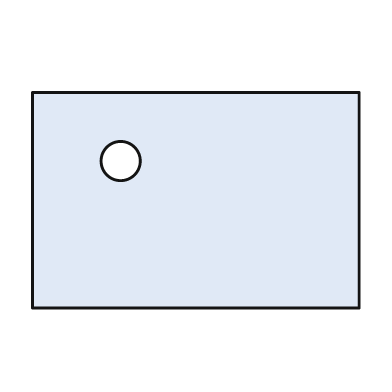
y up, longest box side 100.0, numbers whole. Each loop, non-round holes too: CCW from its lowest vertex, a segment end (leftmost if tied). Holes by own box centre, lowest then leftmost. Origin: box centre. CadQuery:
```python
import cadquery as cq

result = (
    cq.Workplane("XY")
    .moveTo(-50.0, -33.0)
    .lineTo(50.0, -33.0)
    .lineTo(50.0, 33.0)
    .lineTo(-50.0, 33.0)
    .close()
    .moveTo(-23.0, 12.0)
    .circle(6.0)
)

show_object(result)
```